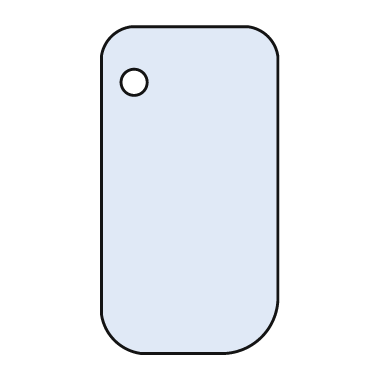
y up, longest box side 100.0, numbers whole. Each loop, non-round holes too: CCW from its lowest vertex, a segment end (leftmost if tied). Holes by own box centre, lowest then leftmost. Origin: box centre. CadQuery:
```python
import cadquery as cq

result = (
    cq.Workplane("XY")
    .moveTo(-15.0, -50.0)
    .lineTo(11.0, -50.0)
    .threePointArc((22.0, -45.0), (27.0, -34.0))
    .lineTo(27.0, 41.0)
    .threePointArc((24.0, 47.0), (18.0, 50.0))
    .lineTo(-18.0, 50.0)
    .threePointArc((-24.0, 47.0), (-27.0, 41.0))
    .lineTo(-27.0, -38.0)
    .threePointArc((-23.0, -46.0), (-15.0, -50.0))
    .close()
    .moveTo(-17.0, 33.0)
    .circle(4.0)
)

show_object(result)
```